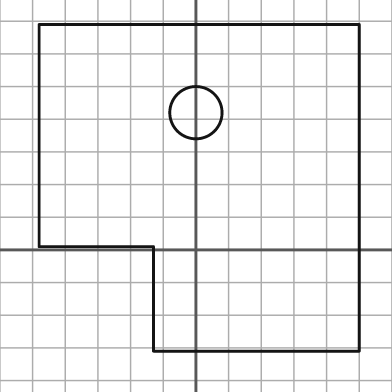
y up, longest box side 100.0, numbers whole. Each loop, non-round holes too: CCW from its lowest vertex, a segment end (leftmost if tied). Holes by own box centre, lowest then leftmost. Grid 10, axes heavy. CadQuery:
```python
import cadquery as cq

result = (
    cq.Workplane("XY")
    .moveTo(-13.0, -31.0)
    .lineTo(50.0, -31.0)
    .lineTo(50.0, 69.0)
    .lineTo(-48.0, 69.0)
    .lineTo(-48.0, 1.0)
    .lineTo(-13.0, 1.0)
    .close()
    .moveTo(0.0, 42.0)
    .circle(8.0)
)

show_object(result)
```